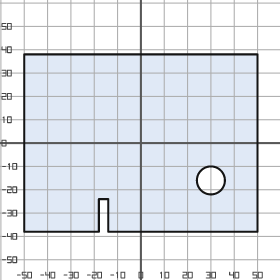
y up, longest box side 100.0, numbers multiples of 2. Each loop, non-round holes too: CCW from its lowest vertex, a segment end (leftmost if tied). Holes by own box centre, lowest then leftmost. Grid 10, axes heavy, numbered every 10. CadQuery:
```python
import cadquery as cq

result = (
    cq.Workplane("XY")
    .moveTo(-50.0, -38.0)
    .lineTo(-18.0, -38.0)
    .lineTo(-18.0, -24.0)
    .lineTo(-14.0, -24.0)
    .lineTo(-14.0, -38.0)
    .lineTo(50.0, -38.0)
    .lineTo(50.0, 38.0)
    .lineTo(-50.0, 38.0)
    .close()
    .moveTo(30.0, -16.0)
    .circle(6.0)
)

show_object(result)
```